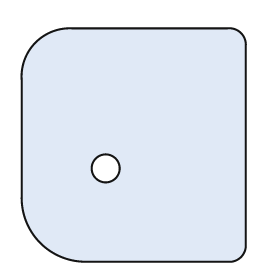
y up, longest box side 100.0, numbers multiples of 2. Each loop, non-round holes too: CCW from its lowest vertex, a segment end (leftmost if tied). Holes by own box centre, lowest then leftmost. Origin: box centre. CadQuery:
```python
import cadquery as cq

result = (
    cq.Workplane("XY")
    .moveTo(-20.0, -50.0)
    .lineTo(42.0, -50.0)
    .threePointArc((46.0, -48.0), (48.0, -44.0))
    .lineTo(48.0, 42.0)
    .threePointArc((46.0, 48.0), (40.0, 50.0))
    .lineTo(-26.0, 50.0)
    .threePointArc((-42.0, 44.0), (-48.0, 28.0))
    .lineTo(-48.0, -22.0)
    .threePointArc((-40.0, -42.0), (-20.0, -50.0))
    .close()
    .moveTo(-12.0, -10.0)
    .circle(6.0)
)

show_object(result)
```